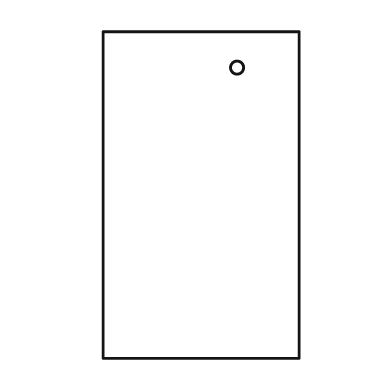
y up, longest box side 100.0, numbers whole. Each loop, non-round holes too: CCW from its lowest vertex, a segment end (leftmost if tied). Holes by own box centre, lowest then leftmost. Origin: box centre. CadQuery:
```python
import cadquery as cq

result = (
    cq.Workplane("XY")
    .moveTo(-30.0, -50.0)
    .lineTo(30.0, -50.0)
    .lineTo(30.0, 50.0)
    .lineTo(-30.0, 50.0)
    .close()
    .moveTo(11.0, 39.0)
    .circle(2.0)
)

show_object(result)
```